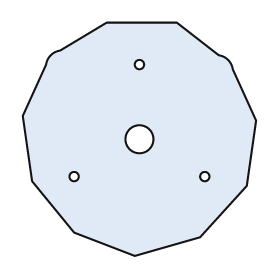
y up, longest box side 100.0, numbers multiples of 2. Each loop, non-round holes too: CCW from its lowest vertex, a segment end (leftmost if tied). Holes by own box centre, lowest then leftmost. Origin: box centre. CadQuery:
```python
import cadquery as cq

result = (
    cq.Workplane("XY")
    .moveTo(-2.0, -50.0)
    .lineTo(26.0, -42.0)
    .lineTo(46.0, -20.0)
    .lineTo(50.0, 8.0)
    .lineTo(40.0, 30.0)
    .threePointArc((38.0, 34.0), (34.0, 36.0))
    .lineTo(16.0, 50.0)
    .lineTo(-14.0, 50.0)
    .lineTo(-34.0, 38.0)
    .threePointArc((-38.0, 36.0), (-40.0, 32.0))
    .lineTo(-50.0, 10.0)
    .lineTo(-46.0, -18.0)
    .lineTo(-28.0, -40.0)
    .close()
    .moveTo(-28.0, -16.0)
    .circle(2.0)
    .moveTo(28.0, -16.0)
    .circle(2.0)
    .moveTo(0.0, 0.0)
    .circle(6.0)
    .moveTo(0.0, 32.0)
    .circle(2.0)
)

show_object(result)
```